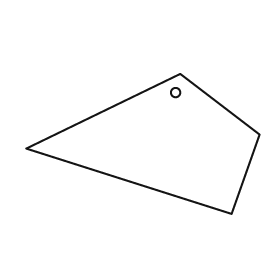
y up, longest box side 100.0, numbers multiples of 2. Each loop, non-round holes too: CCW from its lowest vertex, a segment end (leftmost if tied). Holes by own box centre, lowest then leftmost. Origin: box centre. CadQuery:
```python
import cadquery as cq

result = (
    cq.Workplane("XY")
    .moveTo(38.0, -30.0)
    .lineTo(50.0, 4.0)
    .lineTo(16.0, 30.0)
    .lineTo(-50.0, -2.0)
    .close()
    .moveTo(14.0, 22.0)
    .circle(2.0)
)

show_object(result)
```